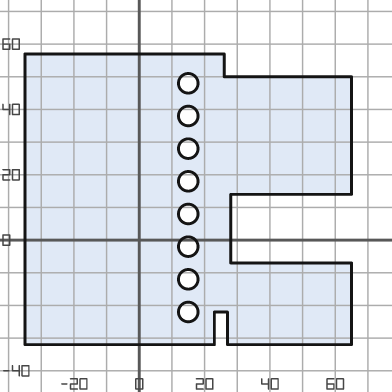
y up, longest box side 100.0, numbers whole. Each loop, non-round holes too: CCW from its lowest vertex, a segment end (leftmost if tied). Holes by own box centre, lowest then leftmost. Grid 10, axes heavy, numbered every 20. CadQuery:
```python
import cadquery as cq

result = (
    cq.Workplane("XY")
    .moveTo(-35.0, -32.0)
    .lineTo(23.0, -32.0)
    .lineTo(23.0, -22.0)
    .lineTo(27.0, -22.0)
    .lineTo(27.0, -32.0)
    .lineTo(65.0, -32.0)
    .lineTo(65.0, -7.0)
    .lineTo(28.0, -7.0)
    .lineTo(28.0, 14.0)
    .lineTo(65.0, 14.0)
    .lineTo(65.0, 50.0)
    .lineTo(26.0, 50.0)
    .lineTo(26.0, 57.0)
    .lineTo(-35.0, 57.0)
    .close()
    .moveTo(15.0, -22.0)
    .circle(3.0)
    .moveTo(15.0, -12.0)
    .circle(3.0)
    .moveTo(15.0, -2.0)
    .circle(3.0)
    .moveTo(15.0, 8.0)
    .circle(3.0)
    .moveTo(15.0, 18.0)
    .circle(3.0)
    .moveTo(15.0, 28.0)
    .circle(3.0)
    .moveTo(15.0, 38.0)
    .circle(3.0)
    .moveTo(15.0, 48.0)
    .circle(3.0)
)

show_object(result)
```